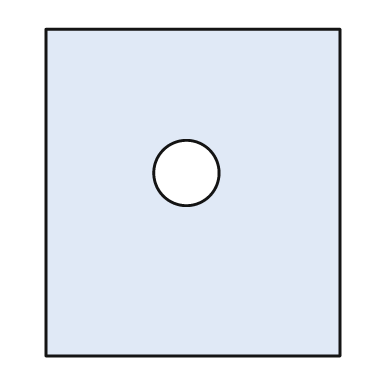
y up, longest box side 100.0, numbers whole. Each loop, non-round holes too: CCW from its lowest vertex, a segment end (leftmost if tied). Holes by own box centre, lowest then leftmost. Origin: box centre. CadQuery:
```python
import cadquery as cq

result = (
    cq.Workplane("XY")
    .moveTo(-45.0, -50.0)
    .lineTo(45.0, -50.0)
    .lineTo(45.0, 50.0)
    .lineTo(-45.0, 50.0)
    .close()
    .moveTo(-2.0, 6.0)
    .circle(10.0)
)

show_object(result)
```